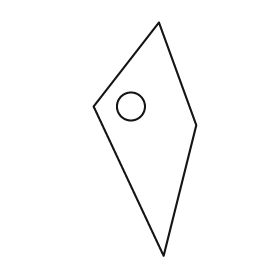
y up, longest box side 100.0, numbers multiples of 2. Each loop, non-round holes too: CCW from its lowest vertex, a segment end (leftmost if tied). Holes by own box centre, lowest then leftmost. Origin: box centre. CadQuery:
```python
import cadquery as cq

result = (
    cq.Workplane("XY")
    .moveTo(8.0, -50.0)
    .lineTo(22.0, 6.0)
    .lineTo(6.0, 50.0)
    .lineTo(-22.0, 14.0)
    .close()
    .moveTo(-6.0, 14.0)
    .circle(6.0)
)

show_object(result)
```